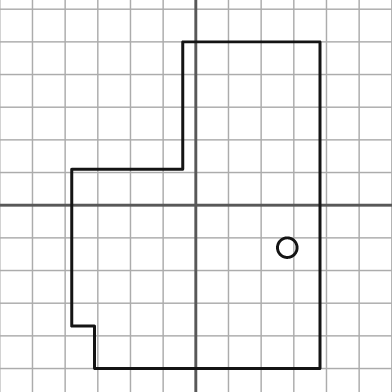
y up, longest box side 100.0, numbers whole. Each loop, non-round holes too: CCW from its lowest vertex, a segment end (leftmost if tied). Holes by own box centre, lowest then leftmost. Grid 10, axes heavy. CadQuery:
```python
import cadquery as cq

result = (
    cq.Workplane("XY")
    .moveTo(-31.0, -50.0)
    .lineTo(38.0, -50.0)
    .lineTo(38.0, 50.0)
    .lineTo(-4.0, 50.0)
    .lineTo(-4.0, 11.0)
    .lineTo(-38.0, 11.0)
    .lineTo(-38.0, -37.0)
    .lineTo(-31.0, -37.0)
    .close()
    .moveTo(28.0, -13.0)
    .circle(3.0)
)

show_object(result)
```